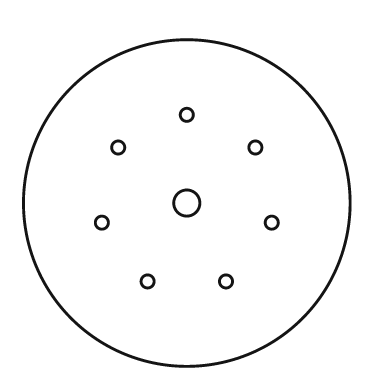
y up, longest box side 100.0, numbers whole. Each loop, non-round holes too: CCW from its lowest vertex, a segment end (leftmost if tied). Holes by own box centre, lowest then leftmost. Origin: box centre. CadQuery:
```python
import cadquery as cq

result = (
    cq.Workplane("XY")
    .moveTo(0.0, 0.0)
    .circle(50.0)
    .moveTo(-12.0, -24.0)
    .circle(2.0)
    .moveTo(12.0, -24.0)
    .circle(2.0)
    .moveTo(-26.0, -6.0)
    .circle(2.0)
    .moveTo(26.0, -6.0)
    .circle(2.0)
    .moveTo(0.0, 0.0)
    .circle(4.0)
    .moveTo(-21.0, 17.0)
    .circle(2.0)
    .moveTo(21.0, 17.0)
    .circle(2.0)
    .moveTo(0.0, 27.0)
    .circle(2.0)
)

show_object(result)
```